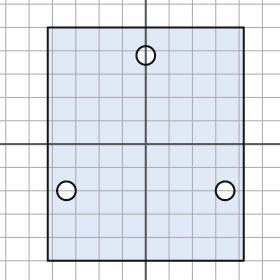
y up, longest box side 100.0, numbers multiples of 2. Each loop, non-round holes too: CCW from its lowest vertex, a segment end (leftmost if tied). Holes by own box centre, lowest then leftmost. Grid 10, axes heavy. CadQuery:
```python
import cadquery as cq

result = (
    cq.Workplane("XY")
    .moveTo(-42.0, -50.0)
    .lineTo(42.0, -50.0)
    .lineTo(42.0, 50.0)
    .lineTo(-42.0, 50.0)
    .close()
    .moveTo(-34.0, -20.0)
    .circle(4.0)
    .moveTo(34.0, -20.0)
    .circle(4.0)
    .moveTo(0.0, 38.0)
    .circle(4.0)
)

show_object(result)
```